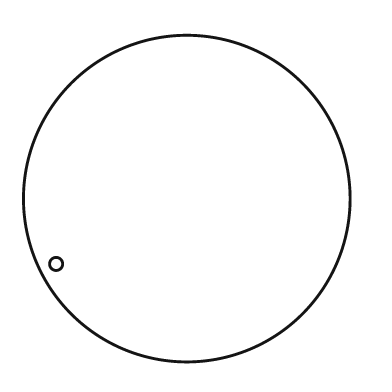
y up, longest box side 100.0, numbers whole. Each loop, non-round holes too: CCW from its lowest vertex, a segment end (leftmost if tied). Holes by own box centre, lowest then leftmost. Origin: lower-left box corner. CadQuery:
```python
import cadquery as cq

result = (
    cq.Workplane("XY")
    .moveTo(50.0, 50.0)
    .circle(50.0)
    .moveTo(10.0, 30.0)
    .circle(2.0)
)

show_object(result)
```